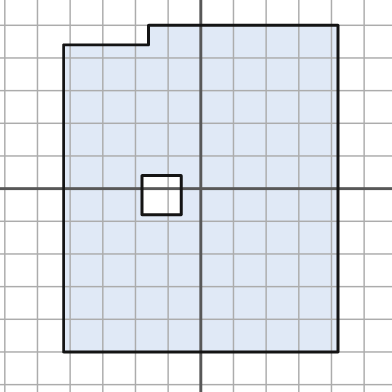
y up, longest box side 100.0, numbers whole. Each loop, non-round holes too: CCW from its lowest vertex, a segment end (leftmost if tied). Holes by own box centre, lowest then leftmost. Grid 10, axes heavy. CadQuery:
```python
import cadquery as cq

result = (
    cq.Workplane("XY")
    .moveTo(-42.0, -50.0)
    .lineTo(42.0, -50.0)
    .lineTo(42.0, 50.0)
    .lineTo(-16.0, 50.0)
    .lineTo(-16.0, 44.0)
    .lineTo(-42.0, 44.0)
    .close()
    .moveTo(-18.0, -8.0)
    .lineTo(-6.0, -8.0)
    .lineTo(-6.0, 4.0)
    .lineTo(-18.0, 4.0)
    .close()
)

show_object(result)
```